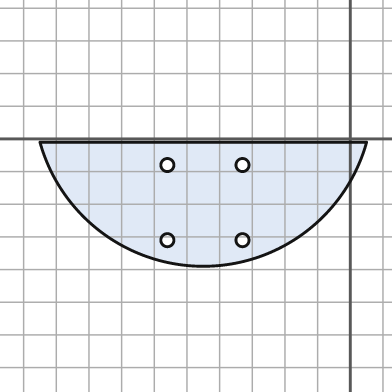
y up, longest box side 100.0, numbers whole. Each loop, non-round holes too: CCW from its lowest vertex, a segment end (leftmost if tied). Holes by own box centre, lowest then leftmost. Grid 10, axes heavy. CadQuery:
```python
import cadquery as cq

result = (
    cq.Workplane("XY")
    .moveTo(-95.0, -1.0)
    .threePointArc((-45.0, -39.0), (5.0, -1.0))
    .close()
    .moveTo(-56.0, -31.0)
    .circle(2.0)
    .moveTo(-33.0, -31.0)
    .circle(2.0)
    .moveTo(-56.0, -8.0)
    .circle(2.0)
    .moveTo(-33.0, -8.0)
    .circle(2.0)
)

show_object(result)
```